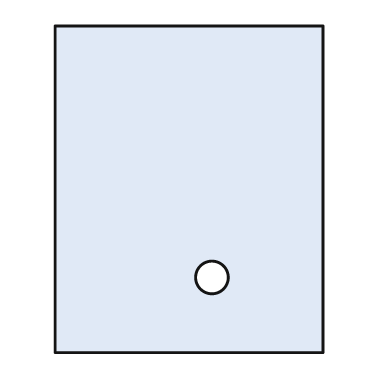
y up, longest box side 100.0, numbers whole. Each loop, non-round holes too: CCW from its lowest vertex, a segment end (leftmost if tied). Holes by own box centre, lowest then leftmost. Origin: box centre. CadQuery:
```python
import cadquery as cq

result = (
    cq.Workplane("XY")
    .moveTo(-41.0, -50.0)
    .lineTo(41.0, -50.0)
    .lineTo(41.0, 50.0)
    .lineTo(-41.0, 50.0)
    .close()
    .moveTo(7.0, -27.0)
    .circle(5.0)
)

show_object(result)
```